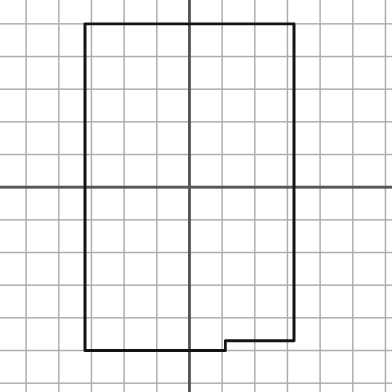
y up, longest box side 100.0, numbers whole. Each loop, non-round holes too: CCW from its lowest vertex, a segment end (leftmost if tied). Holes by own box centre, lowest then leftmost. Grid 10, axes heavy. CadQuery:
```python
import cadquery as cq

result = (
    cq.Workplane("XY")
    .moveTo(-32.0, -50.0)
    .lineTo(11.0, -50.0)
    .lineTo(11.0, -47.0)
    .lineTo(32.0, -47.0)
    .lineTo(32.0, 50.0)
    .lineTo(-32.0, 50.0)
    .close()
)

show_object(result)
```